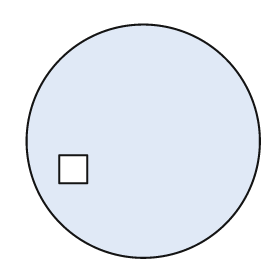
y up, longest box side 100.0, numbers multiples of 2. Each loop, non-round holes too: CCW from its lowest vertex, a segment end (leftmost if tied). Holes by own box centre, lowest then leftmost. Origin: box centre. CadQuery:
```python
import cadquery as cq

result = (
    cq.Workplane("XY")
    .moveTo(0.0, 0.0)
    .circle(50.0)
    .moveTo(-36.0, -18.0)
    .lineTo(-24.0, -18.0)
    .lineTo(-24.0, -6.0)
    .lineTo(-36.0, -6.0)
    .close()
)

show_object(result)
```